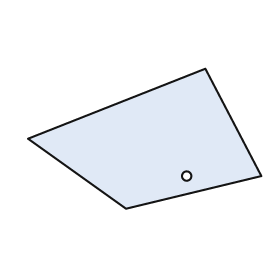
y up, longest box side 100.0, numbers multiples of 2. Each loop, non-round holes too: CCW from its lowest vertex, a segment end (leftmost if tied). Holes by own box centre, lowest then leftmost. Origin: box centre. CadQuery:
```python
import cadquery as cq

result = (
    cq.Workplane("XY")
    .moveTo(-8.0, -30.0)
    .lineTo(50.0, -16.0)
    .lineTo(26.0, 30.0)
    .lineTo(-50.0, 0.0)
    .close()
    .moveTo(18.0, -16.0)
    .circle(2.0)
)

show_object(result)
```